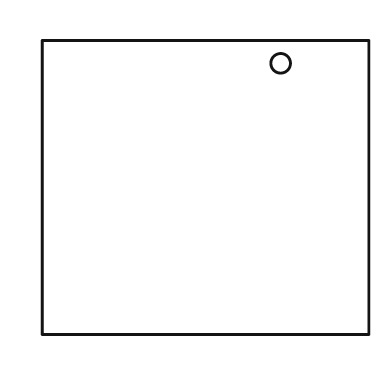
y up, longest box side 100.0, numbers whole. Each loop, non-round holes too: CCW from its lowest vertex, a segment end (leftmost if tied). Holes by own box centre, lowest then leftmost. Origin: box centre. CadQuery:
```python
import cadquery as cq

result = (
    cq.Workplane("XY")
    .moveTo(-50.0, -45.0)
    .lineTo(50.0, -45.0)
    .lineTo(50.0, 45.0)
    .lineTo(-50.0, 45.0)
    .close()
    .moveTo(23.0, 38.0)
    .circle(3.0)
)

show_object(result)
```